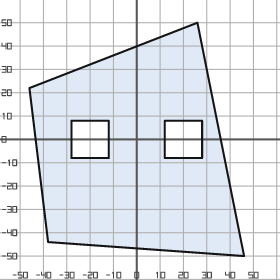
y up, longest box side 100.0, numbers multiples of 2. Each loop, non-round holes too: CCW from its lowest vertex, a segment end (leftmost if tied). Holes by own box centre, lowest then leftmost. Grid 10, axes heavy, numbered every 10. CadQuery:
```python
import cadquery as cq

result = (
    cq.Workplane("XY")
    .moveTo(46.0, -50.0)
    .lineTo(26.0, 50.0)
    .lineTo(-46.0, 22.0)
    .lineTo(-38.0, -44.0)
    .close()
    .moveTo(-28.0, -8.0)
    .lineTo(-12.0, -8.0)
    .lineTo(-12.0, 8.0)
    .lineTo(-28.0, 8.0)
    .close()
    .moveTo(12.0, -8.0)
    .lineTo(28.0, -8.0)
    .lineTo(28.0, 8.0)
    .lineTo(12.0, 8.0)
    .close()
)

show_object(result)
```